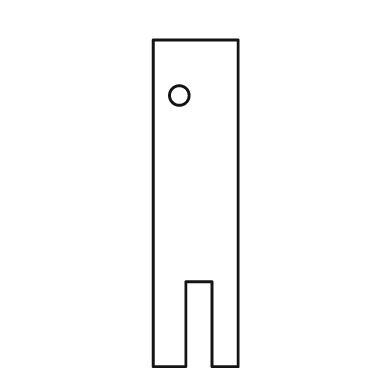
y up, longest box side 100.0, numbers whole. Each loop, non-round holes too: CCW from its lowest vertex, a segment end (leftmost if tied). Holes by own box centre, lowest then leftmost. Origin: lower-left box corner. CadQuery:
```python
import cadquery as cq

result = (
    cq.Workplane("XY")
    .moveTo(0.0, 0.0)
    .lineTo(10.0, 0.0)
    .lineTo(10.0, 26.0)
    .lineTo(18.0, 26.0)
    .lineTo(18.0, 0.0)
    .lineTo(26.0, 0.0)
    .lineTo(26.0, 100.0)
    .lineTo(0.0, 100.0)
    .close()
    .moveTo(8.0, 83.0)
    .circle(3.0)
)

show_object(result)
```